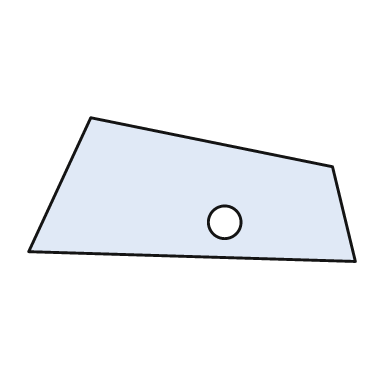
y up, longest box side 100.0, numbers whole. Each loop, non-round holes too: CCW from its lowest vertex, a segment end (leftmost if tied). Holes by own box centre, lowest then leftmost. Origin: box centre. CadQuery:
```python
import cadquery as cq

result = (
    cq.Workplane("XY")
    .moveTo(50.0, -22.0)
    .lineTo(43.0, 7.0)
    .lineTo(-31.0, 22.0)
    .lineTo(-50.0, -19.0)
    .close()
    .moveTo(10.0, -10.0)
    .circle(5.0)
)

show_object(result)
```